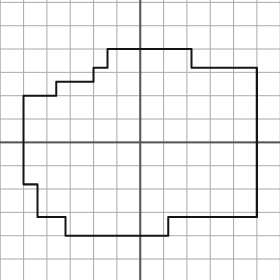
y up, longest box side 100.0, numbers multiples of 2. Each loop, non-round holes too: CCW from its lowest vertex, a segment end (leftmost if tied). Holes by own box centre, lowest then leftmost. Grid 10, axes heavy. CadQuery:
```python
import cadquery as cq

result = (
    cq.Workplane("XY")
    .moveTo(-32.0, -40.0)
    .lineTo(12.0, -40.0)
    .lineTo(12.0, -32.0)
    .lineTo(50.0, -32.0)
    .lineTo(50.0, 32.0)
    .lineTo(22.0, 32.0)
    .lineTo(22.0, 40.0)
    .lineTo(-14.0, 40.0)
    .lineTo(-14.0, 32.0)
    .lineTo(-20.0, 32.0)
    .lineTo(-20.0, 26.0)
    .lineTo(-36.0, 26.0)
    .lineTo(-36.0, 20.0)
    .lineTo(-50.0, 20.0)
    .lineTo(-50.0, -18.0)
    .lineTo(-44.0, -18.0)
    .lineTo(-44.0, -32.0)
    .lineTo(-32.0, -32.0)
    .close()
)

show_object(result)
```